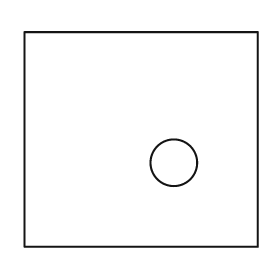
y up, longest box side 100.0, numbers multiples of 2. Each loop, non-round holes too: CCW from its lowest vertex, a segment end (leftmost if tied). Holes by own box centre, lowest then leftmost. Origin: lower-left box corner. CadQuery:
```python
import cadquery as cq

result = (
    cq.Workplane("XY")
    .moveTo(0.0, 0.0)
    .lineTo(100.0, 0.0)
    .lineTo(100.0, 92.0)
    .lineTo(0.0, 92.0)
    .close()
    .moveTo(64.0, 36.0)
    .circle(10.0)
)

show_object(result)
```